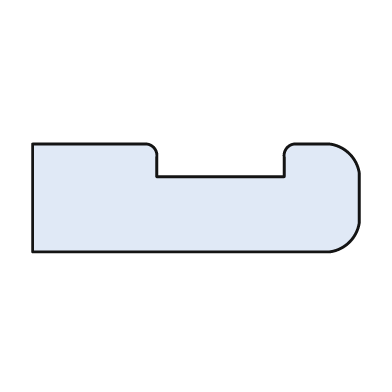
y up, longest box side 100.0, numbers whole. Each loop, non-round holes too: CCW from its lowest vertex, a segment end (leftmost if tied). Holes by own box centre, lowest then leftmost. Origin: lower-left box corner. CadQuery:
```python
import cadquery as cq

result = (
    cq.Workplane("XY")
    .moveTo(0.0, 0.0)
    .lineTo(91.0, 0.0)
    .threePointArc((97.0, 3.0), (100.0, 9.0))
    .lineTo(100.0, 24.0)
    .threePointArc((97.0, 30.0), (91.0, 33.0))
    .lineTo(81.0, 33.0)
    .threePointArc((78.0, 32.0), (77.0, 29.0))
    .lineTo(77.0, 23.0)
    .lineTo(38.0, 23.0)
    .lineTo(38.0, 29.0)
    .threePointArc((37.0, 32.0), (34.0, 33.0))
    .lineTo(0.0, 33.0)
    .close()
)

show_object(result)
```